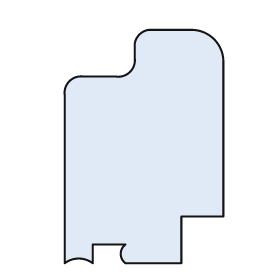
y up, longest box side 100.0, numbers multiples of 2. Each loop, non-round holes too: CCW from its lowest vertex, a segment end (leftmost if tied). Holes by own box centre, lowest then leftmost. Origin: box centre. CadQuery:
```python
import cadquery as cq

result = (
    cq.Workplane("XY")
    .moveTo(-34.0, -50.0)
    .threePointArc((-28.0, -48.0), (-22.0, -50.0))
    .lineTo(-22.0, -42.0)
    .lineTo(-8.0, -42.0)
    .threePointArc((-10.0, -46.0), (-8.0, -50.0))
    .lineTo(16.0, -50.0)
    .lineTo(16.0, -30.0)
    .lineTo(34.0, -30.0)
    .lineTo(34.0, 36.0)
    .threePointArc((30.0, 46.0), (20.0, 50.0))
    .lineTo(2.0, 50.0)
    .threePointArc((-2.0, 48.0), (-4.0, 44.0))
    .lineTo(-4.0, 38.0)
    .threePointArc((-6.0, 32.0), (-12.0, 30.0))
    .lineTo(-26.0, 30.0)
    .threePointArc((-32.0, 28.0), (-34.0, 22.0))
    .close()
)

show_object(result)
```